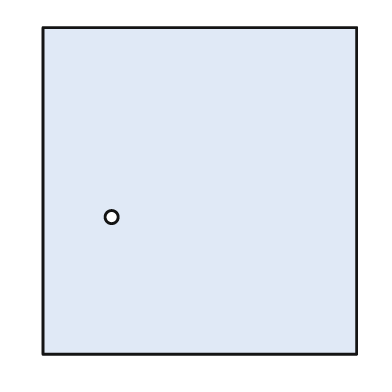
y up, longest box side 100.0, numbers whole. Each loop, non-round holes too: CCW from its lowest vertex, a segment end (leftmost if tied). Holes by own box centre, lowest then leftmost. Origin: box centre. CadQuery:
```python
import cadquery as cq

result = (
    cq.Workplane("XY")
    .moveTo(-48.0, -50.0)
    .lineTo(48.0, -50.0)
    .lineTo(48.0, 50.0)
    .lineTo(-48.0, 50.0)
    .close()
    .moveTo(-27.0, -8.0)
    .circle(2.0)
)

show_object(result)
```